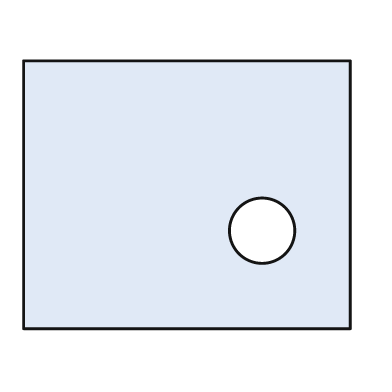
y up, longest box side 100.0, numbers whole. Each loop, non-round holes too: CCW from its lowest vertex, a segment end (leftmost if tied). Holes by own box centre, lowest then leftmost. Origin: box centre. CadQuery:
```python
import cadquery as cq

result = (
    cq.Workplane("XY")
    .moveTo(-50.0, -41.0)
    .lineTo(50.0, -41.0)
    .lineTo(50.0, 41.0)
    .lineTo(-50.0, 41.0)
    .close()
    .moveTo(23.0, -11.0)
    .circle(10.0)
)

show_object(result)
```